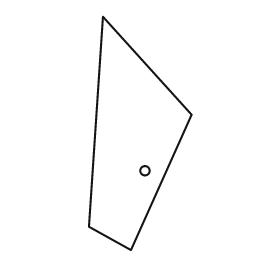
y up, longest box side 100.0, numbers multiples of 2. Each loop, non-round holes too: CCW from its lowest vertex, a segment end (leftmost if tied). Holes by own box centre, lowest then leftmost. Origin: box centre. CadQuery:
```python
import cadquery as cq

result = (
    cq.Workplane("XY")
    .moveTo(-4.0, -50.0)
    .lineTo(22.0, 8.0)
    .lineTo(-16.0, 50.0)
    .lineTo(-22.0, -40.0)
    .close()
    .moveTo(2.0, -16.0)
    .circle(2.0)
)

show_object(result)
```